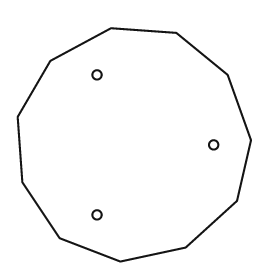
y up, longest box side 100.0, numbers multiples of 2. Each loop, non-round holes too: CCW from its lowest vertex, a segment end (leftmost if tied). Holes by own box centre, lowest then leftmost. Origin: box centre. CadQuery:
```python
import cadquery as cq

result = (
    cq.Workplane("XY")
    .moveTo(-6.0, -50.0)
    .lineTo(22.0, -44.0)
    .lineTo(44.0, -24.0)
    .lineTo(50.0, 2.0)
    .lineTo(40.0, 30.0)
    .lineTo(18.0, 48.0)
    .lineTo(-10.0, 50.0)
    .lineTo(-36.0, 36.0)
    .lineTo(-50.0, 12.0)
    .lineTo(-48.0, -16.0)
    .lineTo(-32.0, -40.0)
    .close()
    .moveTo(-16.0, -30.0)
    .circle(2.0)
    .moveTo(34.0, 0.0)
    .circle(2.0)
    .moveTo(-16.0, 30.0)
    .circle(2.0)
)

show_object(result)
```